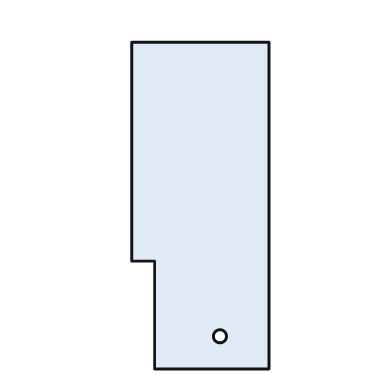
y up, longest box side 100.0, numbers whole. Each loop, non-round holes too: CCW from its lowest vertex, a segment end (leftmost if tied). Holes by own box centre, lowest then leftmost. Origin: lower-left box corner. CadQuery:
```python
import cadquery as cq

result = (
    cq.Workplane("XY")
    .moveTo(7.0, 0.0)
    .lineTo(42.0, 0.0)
    .lineTo(42.0, 100.0)
    .lineTo(0.0, 100.0)
    .lineTo(0.0, 33.0)
    .lineTo(7.0, 33.0)
    .close()
    .moveTo(27.0, 10.0)
    .circle(2.0)
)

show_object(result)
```